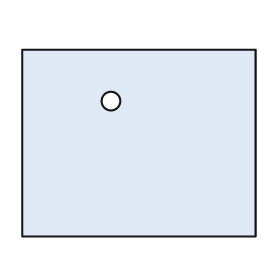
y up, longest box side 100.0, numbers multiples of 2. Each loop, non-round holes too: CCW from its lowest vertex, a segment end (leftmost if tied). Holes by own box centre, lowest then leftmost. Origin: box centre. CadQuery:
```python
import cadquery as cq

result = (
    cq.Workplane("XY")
    .moveTo(-50.0, -40.0)
    .lineTo(50.0, -40.0)
    .lineTo(50.0, 40.0)
    .lineTo(-50.0, 40.0)
    .close()
    .moveTo(-12.0, 18.0)
    .circle(4.0)
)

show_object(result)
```